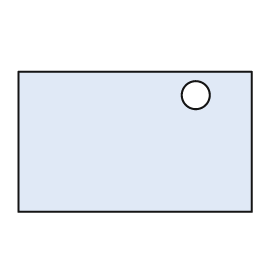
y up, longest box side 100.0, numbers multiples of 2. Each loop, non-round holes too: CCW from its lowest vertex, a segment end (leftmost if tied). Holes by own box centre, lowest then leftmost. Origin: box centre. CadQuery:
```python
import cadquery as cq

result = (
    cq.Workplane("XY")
    .moveTo(-50.0, -30.0)
    .lineTo(50.0, -30.0)
    .lineTo(50.0, 30.0)
    .lineTo(-50.0, 30.0)
    .close()
    .moveTo(26.0, 20.0)
    .circle(6.0)
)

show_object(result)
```